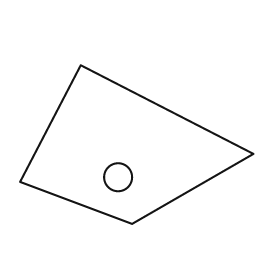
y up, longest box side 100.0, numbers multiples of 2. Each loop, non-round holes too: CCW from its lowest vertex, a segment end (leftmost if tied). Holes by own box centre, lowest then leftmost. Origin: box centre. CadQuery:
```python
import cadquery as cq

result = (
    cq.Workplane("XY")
    .moveTo(-2.0, -34.0)
    .lineTo(50.0, -4.0)
    .lineTo(-24.0, 34.0)
    .lineTo(-50.0, -16.0)
    .close()
    .moveTo(-8.0, -14.0)
    .circle(6.0)
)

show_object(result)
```